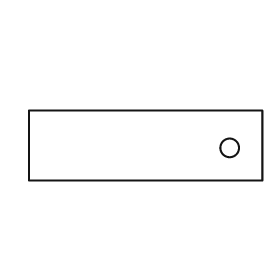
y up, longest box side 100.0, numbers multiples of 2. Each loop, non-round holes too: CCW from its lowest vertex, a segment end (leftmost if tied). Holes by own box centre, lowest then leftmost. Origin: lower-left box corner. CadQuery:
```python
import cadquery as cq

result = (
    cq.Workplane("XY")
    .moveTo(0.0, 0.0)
    .lineTo(100.0, 0.0)
    .lineTo(100.0, 30.0)
    .lineTo(0.0, 30.0)
    .close()
    .moveTo(86.0, 14.0)
    .circle(4.0)
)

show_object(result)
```